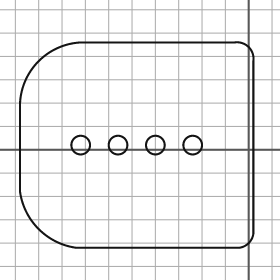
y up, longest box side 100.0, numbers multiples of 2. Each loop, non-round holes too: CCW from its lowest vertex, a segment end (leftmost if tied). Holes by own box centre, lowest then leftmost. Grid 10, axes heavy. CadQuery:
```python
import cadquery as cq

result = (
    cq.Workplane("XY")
    .moveTo(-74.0, -42.0)
    .lineTo(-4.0, -42.0)
    .threePointArc((0.0, -40.0), (2.0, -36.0))
    .lineTo(2.0, 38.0)
    .threePointArc((0.0, 44.0), (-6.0, 46.0))
    .lineTo(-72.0, 46.0)
    .threePointArc((-90.0, 38.0), (-98.0, 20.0))
    .lineTo(-98.0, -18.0)
    .threePointArc((-90.0, -34.0), (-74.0, -42.0))
    .close()
    .moveTo(-72.0, 2.0)
    .circle(4.0)
    .moveTo(-56.0, 2.0)
    .circle(4.0)
    .moveTo(-40.0, 2.0)
    .circle(4.0)
    .moveTo(-24.0, 2.0)
    .circle(4.0)
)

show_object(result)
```